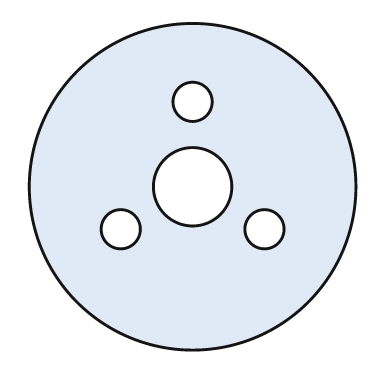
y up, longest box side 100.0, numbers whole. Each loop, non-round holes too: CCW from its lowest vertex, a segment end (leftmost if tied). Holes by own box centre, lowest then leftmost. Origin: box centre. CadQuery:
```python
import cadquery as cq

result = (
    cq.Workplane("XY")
    .moveTo(0.0, 0.0)
    .circle(50.0)
    .moveTo(-22.0, -13.0)
    .circle(6.0)
    .moveTo(22.0, -13.0)
    .circle(6.0)
    .moveTo(0.0, 0.0)
    .circle(12.0)
    .moveTo(0.0, 26.0)
    .circle(6.0)
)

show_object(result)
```